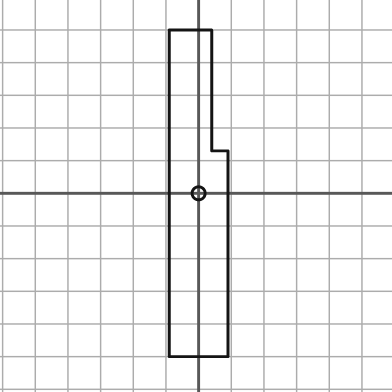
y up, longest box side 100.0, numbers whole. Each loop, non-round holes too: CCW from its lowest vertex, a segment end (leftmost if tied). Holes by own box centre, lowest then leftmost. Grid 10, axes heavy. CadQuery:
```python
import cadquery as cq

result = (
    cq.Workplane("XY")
    .moveTo(-9.0, -50.0)
    .lineTo(9.0, -50.0)
    .lineTo(9.0, 13.0)
    .lineTo(4.0, 13.0)
    .lineTo(4.0, 50.0)
    .lineTo(-9.0, 50.0)
    .close()
    .moveTo(0.0, 0.0)
    .circle(2.0)
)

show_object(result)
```